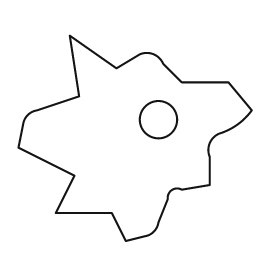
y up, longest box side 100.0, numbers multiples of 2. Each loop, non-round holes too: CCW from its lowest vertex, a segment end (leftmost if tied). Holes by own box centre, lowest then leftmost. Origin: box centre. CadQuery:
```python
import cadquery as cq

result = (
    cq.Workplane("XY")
    .moveTo(-4.0, -44.0)
    .lineTo(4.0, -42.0)
    .threePointArc((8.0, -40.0), (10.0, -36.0))
    .lineTo(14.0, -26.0)
    .threePointArc((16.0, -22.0), (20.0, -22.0))
    .lineTo(32.0, -20.0)
    .lineTo(32.0, -8.0)
    .threePointArc((32.0, -2.0), (36.0, 2.0))
    .threePointArc((44.0, 6.0), (50.0, 12.0))
    .lineTo(40.0, 24.0)
    .lineTo(20.0, 24.0)
    .lineTo(12.0, 32.0)
    .threePointArc((8.0, 36.0), (2.0, 36.0))
    .lineTo(-8.0, 30.0)
    .lineTo(-28.0, 44.0)
    .lineTo(-24.0, 18.0)
    .lineTo(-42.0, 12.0)
    .threePointArc((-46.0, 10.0), (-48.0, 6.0))
    .lineTo(-50.0, -4.0)
    .lineTo(-26.0, -16.0)
    .lineTo(-34.0, -32.0)
    .lineTo(-10.0, -32.0)
    .close()
    .moveTo(10.0, 8.0)
    .circle(8.0)
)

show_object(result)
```